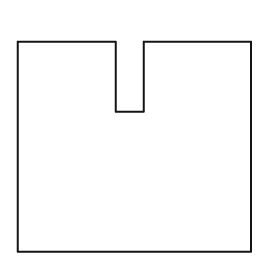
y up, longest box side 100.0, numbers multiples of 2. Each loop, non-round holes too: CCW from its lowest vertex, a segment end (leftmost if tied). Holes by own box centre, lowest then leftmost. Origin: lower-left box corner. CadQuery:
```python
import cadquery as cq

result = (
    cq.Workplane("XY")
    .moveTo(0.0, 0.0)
    .lineTo(100.0, 0.0)
    .lineTo(100.0, 90.0)
    .lineTo(54.0, 90.0)
    .lineTo(54.0, 60.0)
    .lineTo(42.0, 60.0)
    .lineTo(42.0, 90.0)
    .lineTo(0.0, 90.0)
    .close()
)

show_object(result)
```